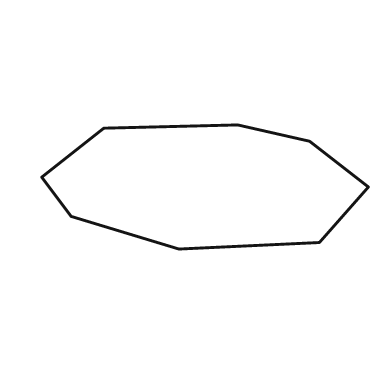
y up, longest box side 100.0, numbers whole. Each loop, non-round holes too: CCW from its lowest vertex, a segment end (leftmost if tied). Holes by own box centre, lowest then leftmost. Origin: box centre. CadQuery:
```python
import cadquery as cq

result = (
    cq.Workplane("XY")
    .moveTo(-8.0, -19.0)
    .lineTo(35.0, -17.0)
    .lineTo(50.0, 0.0)
    .lineTo(32.0, 14.0)
    .lineTo(10.0, 19.0)
    .lineTo(-31.0, 18.0)
    .lineTo(-50.0, 3.0)
    .lineTo(-41.0, -9.0)
    .close()
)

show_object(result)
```